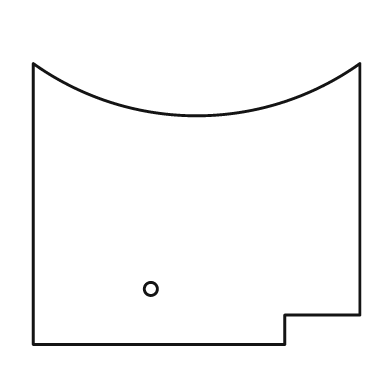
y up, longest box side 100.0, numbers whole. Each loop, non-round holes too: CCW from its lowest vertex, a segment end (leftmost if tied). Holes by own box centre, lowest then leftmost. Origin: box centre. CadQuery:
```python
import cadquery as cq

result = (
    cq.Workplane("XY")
    .moveTo(-50.0, -43.0)
    .lineTo(27.0, -43.0)
    .lineTo(27.0, -34.0)
    .lineTo(50.0, -34.0)
    .lineTo(50.0, 43.0)
    .threePointArc((0.0, 27.0), (-50.0, 43.0))
    .close()
    .moveTo(-14.0, -26.0)
    .circle(2.0)
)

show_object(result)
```